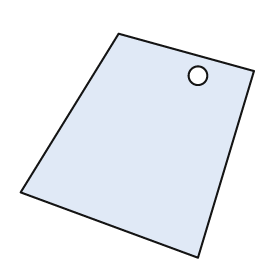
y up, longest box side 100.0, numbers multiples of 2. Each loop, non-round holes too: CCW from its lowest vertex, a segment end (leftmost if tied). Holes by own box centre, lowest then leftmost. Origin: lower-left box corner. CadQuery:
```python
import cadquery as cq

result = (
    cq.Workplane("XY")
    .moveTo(76.0, 0.0)
    .lineTo(100.0, 80.0)
    .lineTo(42.0, 96.0)
    .lineTo(0.0, 28.0)
    .close()
    .moveTo(76.0, 78.0)
    .circle(4.0)
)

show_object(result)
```